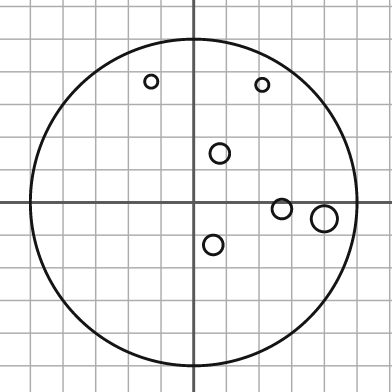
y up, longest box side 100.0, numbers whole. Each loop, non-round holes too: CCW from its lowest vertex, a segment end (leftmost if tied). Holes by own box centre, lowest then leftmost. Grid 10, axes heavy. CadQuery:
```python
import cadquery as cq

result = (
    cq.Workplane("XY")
    .moveTo(0.0, 0.0)
    .circle(50.0)
    .moveTo(6.0, -13.0)
    .circle(3.0)
    .moveTo(40.0, -5.0)
    .circle(4.0)
    .moveTo(27.0, -2.0)
    .circle(3.0)
    .moveTo(8.0, 15.0)
    .circle(3.0)
    .moveTo(21.0, 36.0)
    .circle(2.0)
    .moveTo(-13.0, 37.0)
    .circle(2.0)
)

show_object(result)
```